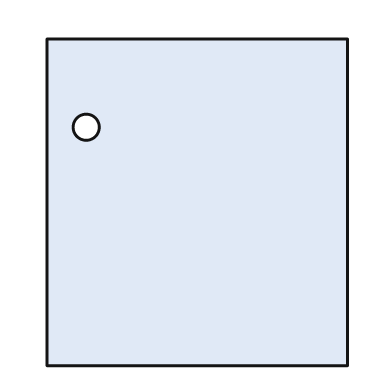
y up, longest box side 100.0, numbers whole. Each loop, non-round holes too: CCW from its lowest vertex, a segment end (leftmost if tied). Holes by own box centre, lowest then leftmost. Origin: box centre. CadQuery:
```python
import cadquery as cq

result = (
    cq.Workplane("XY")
    .moveTo(-46.0, -50.0)
    .lineTo(46.0, -50.0)
    .lineTo(46.0, 50.0)
    .lineTo(-46.0, 50.0)
    .close()
    .moveTo(-34.0, 23.0)
    .circle(4.0)
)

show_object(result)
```